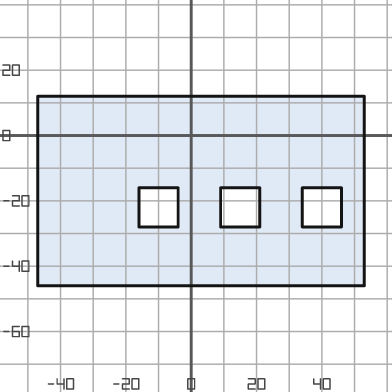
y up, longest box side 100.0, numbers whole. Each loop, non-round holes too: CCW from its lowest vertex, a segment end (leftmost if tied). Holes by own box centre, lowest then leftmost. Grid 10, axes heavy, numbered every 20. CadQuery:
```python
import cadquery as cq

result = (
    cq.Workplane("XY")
    .moveTo(-47.0, -46.0)
    .lineTo(53.0, -46.0)
    .lineTo(53.0, 12.0)
    .lineTo(-47.0, 12.0)
    .close()
    .moveTo(-16.0, -28.0)
    .lineTo(-4.0, -28.0)
    .lineTo(-4.0, -16.0)
    .lineTo(-16.0, -16.0)
    .close()
    .moveTo(9.0, -28.0)
    .lineTo(21.0, -28.0)
    .lineTo(21.0, -16.0)
    .lineTo(9.0, -16.0)
    .close()
    .moveTo(34.0, -28.0)
    .lineTo(46.0, -28.0)
    .lineTo(46.0, -16.0)
    .lineTo(34.0, -16.0)
    .close()
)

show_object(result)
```